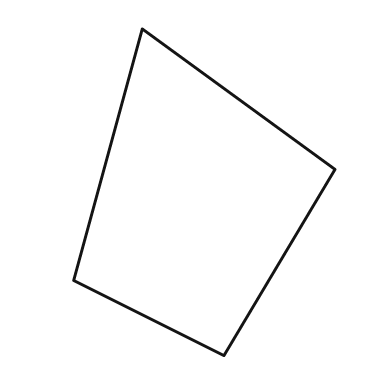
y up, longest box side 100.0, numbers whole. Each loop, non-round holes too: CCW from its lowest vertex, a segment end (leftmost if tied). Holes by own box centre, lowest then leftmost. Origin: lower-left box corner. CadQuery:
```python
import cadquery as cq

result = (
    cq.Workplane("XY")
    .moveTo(46.0, 0.0)
    .lineTo(80.0, 57.0)
    .lineTo(21.0, 100.0)
    .lineTo(0.0, 23.0)
    .close()
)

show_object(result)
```